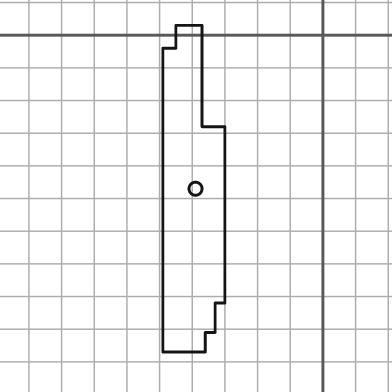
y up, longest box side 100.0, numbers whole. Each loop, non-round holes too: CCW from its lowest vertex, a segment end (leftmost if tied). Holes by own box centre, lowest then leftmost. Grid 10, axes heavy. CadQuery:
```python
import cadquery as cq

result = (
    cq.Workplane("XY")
    .moveTo(-49.0, -97.0)
    .lineTo(-36.0, -97.0)
    .lineTo(-36.0, -91.0)
    .lineTo(-33.0, -91.0)
    .lineTo(-33.0, -82.0)
    .lineTo(-30.0, -82.0)
    .lineTo(-30.0, -28.0)
    .lineTo(-37.0, -28.0)
    .lineTo(-37.0, 3.0)
    .lineTo(-45.0, 3.0)
    .lineTo(-45.0, -4.0)
    .lineTo(-49.0, -4.0)
    .close()
    .moveTo(-39.0, -47.0)
    .circle(2.0)
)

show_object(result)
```